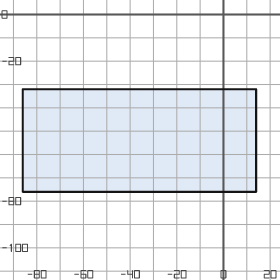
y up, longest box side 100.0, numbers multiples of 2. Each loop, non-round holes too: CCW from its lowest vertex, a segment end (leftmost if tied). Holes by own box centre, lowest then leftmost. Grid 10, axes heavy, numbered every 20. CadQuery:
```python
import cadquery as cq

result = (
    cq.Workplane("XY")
    .moveTo(-86.0, -76.0)
    .lineTo(14.0, -76.0)
    .lineTo(14.0, -32.0)
    .lineTo(-86.0, -32.0)
    .close()
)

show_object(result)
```